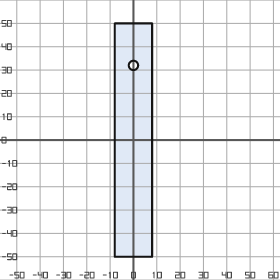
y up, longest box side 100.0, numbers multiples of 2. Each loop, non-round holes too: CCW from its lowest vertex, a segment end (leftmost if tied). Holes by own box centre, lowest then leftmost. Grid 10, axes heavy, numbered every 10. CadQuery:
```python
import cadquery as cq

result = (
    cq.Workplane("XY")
    .moveTo(-8.0, -50.0)
    .lineTo(8.0, -50.0)
    .lineTo(8.0, 50.0)
    .lineTo(-8.0, 50.0)
    .close()
    .moveTo(0.0, 32.0)
    .circle(2.0)
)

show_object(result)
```